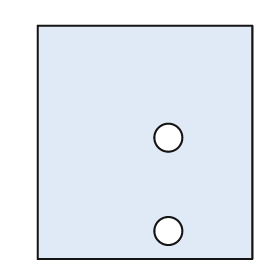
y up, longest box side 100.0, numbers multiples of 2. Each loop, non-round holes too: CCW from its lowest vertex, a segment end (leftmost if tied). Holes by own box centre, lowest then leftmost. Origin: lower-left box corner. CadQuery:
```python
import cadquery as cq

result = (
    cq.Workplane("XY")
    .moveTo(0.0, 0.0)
    .lineTo(92.0, 0.0)
    .lineTo(92.0, 100.0)
    .lineTo(0.0, 100.0)
    .close()
    .moveTo(56.0, 12.0)
    .circle(6.0)
    .moveTo(56.0, 52.0)
    .circle(6.0)
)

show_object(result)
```